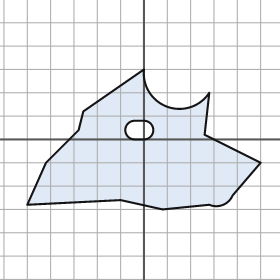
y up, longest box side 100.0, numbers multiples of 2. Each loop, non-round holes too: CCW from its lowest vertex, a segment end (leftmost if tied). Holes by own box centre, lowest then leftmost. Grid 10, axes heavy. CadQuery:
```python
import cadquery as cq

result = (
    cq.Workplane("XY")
    .moveTo(8.0, -30.0)
    .lineTo(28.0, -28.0)
    .threePointArc((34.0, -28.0), (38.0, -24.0))
    .lineTo(50.0, -10.0)
    .lineTo(26.0, 2.0)
    .lineTo(28.0, 20.0)
    .threePointArc((10.0, 14.0), (0.0, 30.0))
    .lineTo(-26.0, 12.0)
    .lineTo(-28.0, 4.0)
    .lineTo(-42.0, -10.0)
    .lineTo(-50.0, -28.0)
    .lineTo(-10.0, -26.0)
    .close()
    .moveTo(-4.0, 0.0)
    .lineTo(0.0, 0.0)
    .threePointArc((4.0, 4.0), (0.0, 8.0))
    .lineTo(-4.0, 8.0)
    .threePointArc((-8.0, 4.0), (-4.0, 0.0))
    .close()
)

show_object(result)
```